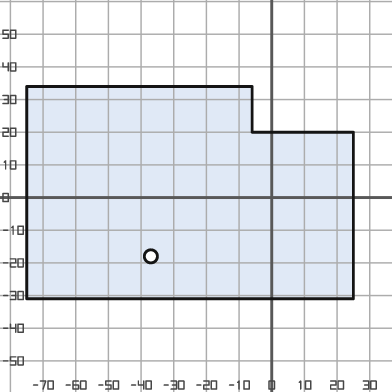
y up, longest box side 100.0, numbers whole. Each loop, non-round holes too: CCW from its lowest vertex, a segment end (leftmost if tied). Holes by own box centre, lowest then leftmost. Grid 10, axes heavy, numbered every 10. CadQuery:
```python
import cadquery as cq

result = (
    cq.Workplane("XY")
    .moveTo(-75.0, -31.0)
    .lineTo(25.0, -31.0)
    .lineTo(25.0, 20.0)
    .lineTo(-6.0, 20.0)
    .lineTo(-6.0, 34.0)
    .lineTo(-75.0, 34.0)
    .close()
    .moveTo(-37.0, -18.0)
    .circle(2.0)
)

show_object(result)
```